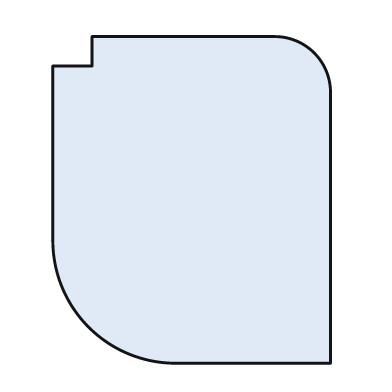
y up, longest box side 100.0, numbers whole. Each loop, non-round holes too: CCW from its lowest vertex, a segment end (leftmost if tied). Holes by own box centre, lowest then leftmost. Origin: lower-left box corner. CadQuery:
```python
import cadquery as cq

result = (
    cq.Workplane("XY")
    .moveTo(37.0, 0.0)
    .lineTo(85.0, 0.0)
    .lineTo(85.0, 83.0)
    .threePointArc((80.0, 95.0), (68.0, 100.0))
    .lineTo(12.0, 100.0)
    .lineTo(12.0, 91.0)
    .lineTo(0.0, 91.0)
    .lineTo(0.0, 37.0)
    .threePointArc((11.0, 11.0), (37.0, 0.0))
    .close()
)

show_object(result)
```